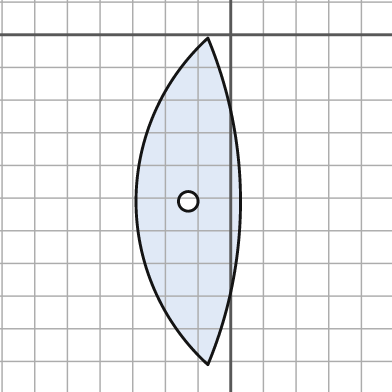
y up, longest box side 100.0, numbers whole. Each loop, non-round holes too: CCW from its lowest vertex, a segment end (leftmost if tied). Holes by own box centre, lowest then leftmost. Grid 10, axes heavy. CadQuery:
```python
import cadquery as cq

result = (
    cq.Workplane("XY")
    .moveTo(-7.0, -101.0)
    .threePointArc((3.0, -51.0), (-7.0, -1.0))
    .threePointArc((-29.0, -51.0), (-7.0, -101.0))
    .close()
    .moveTo(-13.0, -51.0)
    .circle(3.0)
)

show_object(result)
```